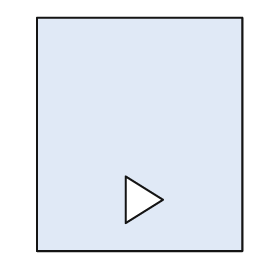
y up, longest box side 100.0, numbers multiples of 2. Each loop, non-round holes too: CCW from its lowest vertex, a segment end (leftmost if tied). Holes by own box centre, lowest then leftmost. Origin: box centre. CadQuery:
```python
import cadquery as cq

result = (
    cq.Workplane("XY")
    .moveTo(-44.0, -50.0)
    .lineTo(44.0, -50.0)
    .lineTo(44.0, 50.0)
    .lineTo(-44.0, 50.0)
    .close()
    .moveTo(-6.0, -38.0)
    .lineTo(10.0, -28.0)
    .lineTo(-6.0, -18.0)
    .close()
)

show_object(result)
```